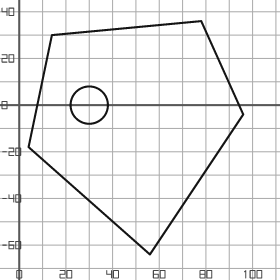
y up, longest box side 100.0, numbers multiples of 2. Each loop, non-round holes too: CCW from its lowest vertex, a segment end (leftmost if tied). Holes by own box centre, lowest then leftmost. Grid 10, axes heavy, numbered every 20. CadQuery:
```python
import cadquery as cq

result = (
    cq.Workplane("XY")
    .moveTo(56.0, -64.0)
    .lineTo(96.0, -4.0)
    .lineTo(78.0, 36.0)
    .lineTo(14.0, 30.0)
    .lineTo(4.0, -18.0)
    .close()
    .moveTo(30.0, 0.0)
    .circle(8.0)
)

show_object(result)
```